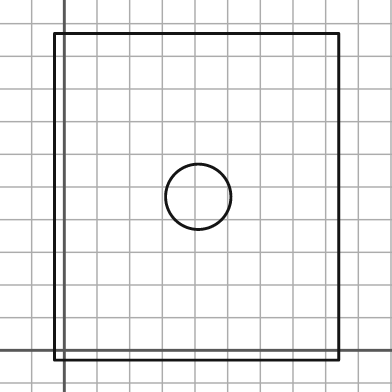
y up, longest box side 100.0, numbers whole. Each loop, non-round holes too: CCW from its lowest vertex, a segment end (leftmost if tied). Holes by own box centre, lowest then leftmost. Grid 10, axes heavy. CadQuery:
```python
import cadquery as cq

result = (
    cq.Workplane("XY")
    .moveTo(-3.0, -3.0)
    .lineTo(84.0, -3.0)
    .lineTo(84.0, 97.0)
    .lineTo(-3.0, 97.0)
    .close()
    .moveTo(41.0, 47.0)
    .circle(10.0)
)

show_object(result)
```